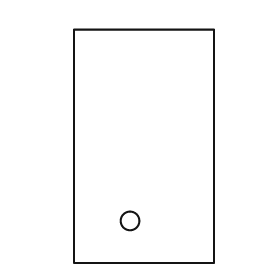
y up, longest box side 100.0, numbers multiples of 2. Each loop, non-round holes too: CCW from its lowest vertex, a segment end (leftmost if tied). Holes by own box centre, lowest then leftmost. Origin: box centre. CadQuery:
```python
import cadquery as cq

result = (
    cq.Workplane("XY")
    .moveTo(-30.0, -50.0)
    .lineTo(30.0, -50.0)
    .lineTo(30.0, 50.0)
    .lineTo(-30.0, 50.0)
    .close()
    .moveTo(-6.0, -32.0)
    .circle(4.0)
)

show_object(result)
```